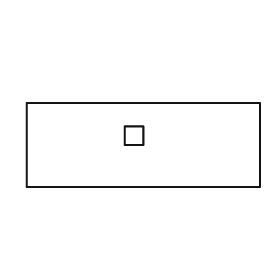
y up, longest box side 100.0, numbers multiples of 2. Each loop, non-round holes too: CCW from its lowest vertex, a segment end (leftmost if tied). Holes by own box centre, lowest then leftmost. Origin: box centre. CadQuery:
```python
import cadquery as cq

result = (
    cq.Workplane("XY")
    .moveTo(-50.0, -18.0)
    .lineTo(50.0, -18.0)
    .lineTo(50.0, 18.0)
    .lineTo(-50.0, 18.0)
    .close()
    .moveTo(-8.0, 0.0)
    .lineTo(0.0, 0.0)
    .lineTo(0.0, 8.0)
    .lineTo(-8.0, 8.0)
    .close()
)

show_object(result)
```